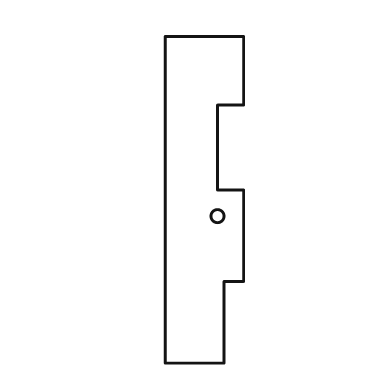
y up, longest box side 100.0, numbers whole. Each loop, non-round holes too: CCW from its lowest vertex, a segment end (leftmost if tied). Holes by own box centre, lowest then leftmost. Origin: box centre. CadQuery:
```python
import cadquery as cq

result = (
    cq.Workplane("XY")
    .moveTo(-12.0, -50.0)
    .lineTo(6.0, -50.0)
    .lineTo(6.0, -25.0)
    .lineTo(12.0, -25.0)
    .lineTo(12.0, 3.0)
    .lineTo(4.0, 3.0)
    .lineTo(4.0, 29.0)
    .lineTo(12.0, 29.0)
    .lineTo(12.0, 50.0)
    .lineTo(-12.0, 50.0)
    .close()
    .moveTo(4.0, -5.0)
    .circle(2.0)
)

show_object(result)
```